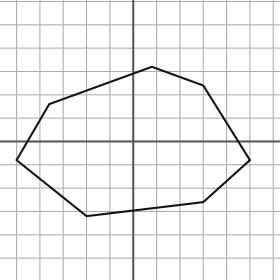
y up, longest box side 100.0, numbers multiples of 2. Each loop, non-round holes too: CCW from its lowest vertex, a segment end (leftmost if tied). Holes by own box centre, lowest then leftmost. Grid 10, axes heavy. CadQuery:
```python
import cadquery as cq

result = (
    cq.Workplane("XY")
    .moveTo(-20.0, -32.0)
    .lineTo(30.0, -26.0)
    .lineTo(50.0, -8.0)
    .lineTo(30.0, 24.0)
    .lineTo(8.0, 32.0)
    .lineTo(-36.0, 16.0)
    .lineTo(-50.0, -8.0)
    .close()
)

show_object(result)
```